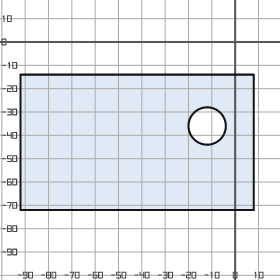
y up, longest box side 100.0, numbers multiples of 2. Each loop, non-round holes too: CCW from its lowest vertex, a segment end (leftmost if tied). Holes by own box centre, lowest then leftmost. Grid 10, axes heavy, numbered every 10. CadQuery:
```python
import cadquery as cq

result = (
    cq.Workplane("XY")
    .moveTo(-92.0, -72.0)
    .lineTo(8.0, -72.0)
    .lineTo(8.0, -14.0)
    .lineTo(-92.0, -14.0)
    .close()
    .moveTo(-12.0, -36.0)
    .circle(8.0)
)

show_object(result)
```